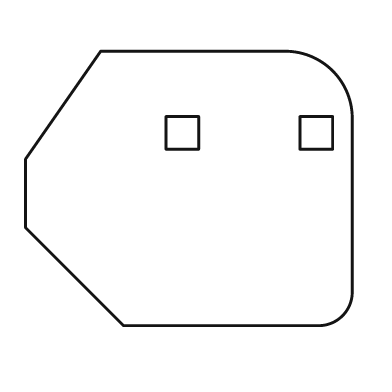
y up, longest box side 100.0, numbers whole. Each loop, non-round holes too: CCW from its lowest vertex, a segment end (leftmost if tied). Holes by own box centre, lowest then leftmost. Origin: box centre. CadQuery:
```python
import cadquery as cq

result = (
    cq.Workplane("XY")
    .moveTo(-20.0, -42.0)
    .lineTo(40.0, -42.0)
    .threePointArc((47.0, -39.0), (50.0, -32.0))
    .lineTo(50.0, 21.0)
    .threePointArc((44.0, 36.0), (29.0, 42.0))
    .lineTo(-27.0, 42.0)
    .lineTo(-50.0, 9.0)
    .lineTo(-50.0, -12.0)
    .close()
    .moveTo(-7.0, 12.0)
    .lineTo(3.0, 12.0)
    .lineTo(3.0, 22.0)
    .lineTo(-7.0, 22.0)
    .close()
    .moveTo(34.0, 12.0)
    .lineTo(44.0, 12.0)
    .lineTo(44.0, 22.0)
    .lineTo(34.0, 22.0)
    .close()
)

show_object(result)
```